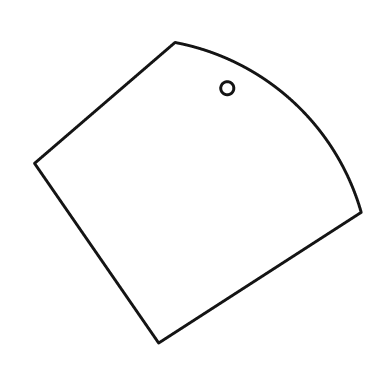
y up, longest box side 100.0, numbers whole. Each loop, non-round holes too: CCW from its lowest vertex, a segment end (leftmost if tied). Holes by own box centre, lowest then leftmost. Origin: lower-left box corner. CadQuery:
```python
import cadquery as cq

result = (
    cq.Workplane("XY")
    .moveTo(38.0, 0.0)
    .lineTo(100.0, 40.0)
    .threePointArc((79.0, 74.0), (43.0, 92.0))
    .lineTo(0.0, 55.0)
    .close()
    .moveTo(59.0, 78.0)
    .circle(2.0)
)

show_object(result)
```